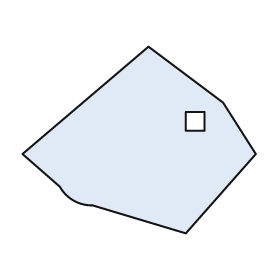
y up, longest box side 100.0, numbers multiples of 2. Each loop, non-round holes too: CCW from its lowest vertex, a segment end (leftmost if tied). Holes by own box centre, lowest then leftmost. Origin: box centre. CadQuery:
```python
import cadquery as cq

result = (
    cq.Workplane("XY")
    .moveTo(20.0, -40.0)
    .lineTo(50.0, -6.0)
    .lineTo(36.0, 16.0)
    .lineTo(4.0, 40.0)
    .lineTo(-50.0, -6.0)
    .lineTo(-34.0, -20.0)
    .threePointArc((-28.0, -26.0), (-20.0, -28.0))
    .close()
    .moveTo(20.0, 4.0)
    .lineTo(28.0, 4.0)
    .lineTo(28.0, 12.0)
    .lineTo(20.0, 12.0)
    .close()
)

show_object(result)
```